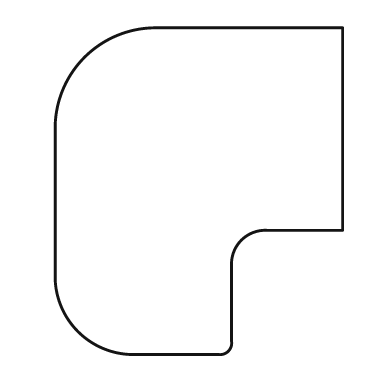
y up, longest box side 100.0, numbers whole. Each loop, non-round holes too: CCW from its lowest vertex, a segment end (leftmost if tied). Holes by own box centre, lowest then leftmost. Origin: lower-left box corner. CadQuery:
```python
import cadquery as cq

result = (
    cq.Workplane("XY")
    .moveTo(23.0, 0.0)
    .lineTo(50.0, 0.0)
    .threePointArc((53.0, 1.0), (54.0, 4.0))
    .lineTo(54.0, 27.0)
    .threePointArc((57.0, 35.0), (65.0, 38.0))
    .lineTo(88.0, 38.0)
    .lineTo(88.0, 100.0)
    .lineTo(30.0, 100.0)
    .threePointArc((9.0, 91.0), (0.0, 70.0))
    .lineTo(0.0, 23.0)
    .threePointArc((7.0, 7.0), (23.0, 0.0))
    .close()
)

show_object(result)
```